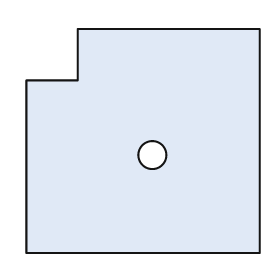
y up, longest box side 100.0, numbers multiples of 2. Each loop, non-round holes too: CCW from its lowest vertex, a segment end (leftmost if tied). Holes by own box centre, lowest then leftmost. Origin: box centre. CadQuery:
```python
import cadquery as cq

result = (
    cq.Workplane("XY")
    .moveTo(-50.0, -48.0)
    .lineTo(50.0, -48.0)
    .lineTo(50.0, 48.0)
    .lineTo(-28.0, 48.0)
    .lineTo(-28.0, 26.0)
    .lineTo(-50.0, 26.0)
    .close()
    .moveTo(4.0, -6.0)
    .circle(6.0)
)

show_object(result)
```